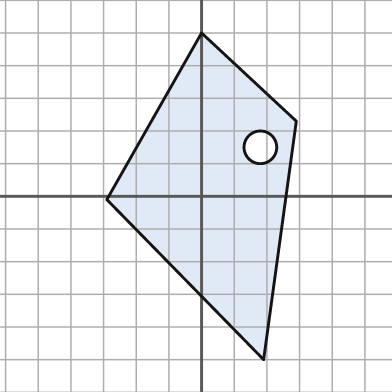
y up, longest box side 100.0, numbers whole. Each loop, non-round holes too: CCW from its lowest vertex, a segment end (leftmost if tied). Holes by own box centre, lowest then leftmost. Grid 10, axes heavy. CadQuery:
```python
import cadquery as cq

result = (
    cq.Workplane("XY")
    .moveTo(19.0, -50.0)
    .lineTo(29.0, 23.0)
    .lineTo(0.0, 50.0)
    .lineTo(-29.0, -1.0)
    .close()
    .moveTo(18.0, 15.0)
    .circle(5.0)
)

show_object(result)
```